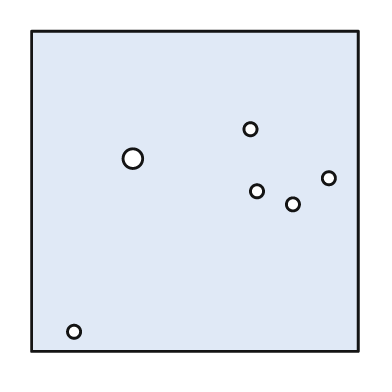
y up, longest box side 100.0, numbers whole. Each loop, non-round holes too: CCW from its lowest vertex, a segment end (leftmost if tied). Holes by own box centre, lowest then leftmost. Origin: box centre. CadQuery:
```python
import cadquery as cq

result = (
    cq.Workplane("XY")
    .moveTo(-50.0, -49.0)
    .lineTo(50.0, -49.0)
    .lineTo(50.0, 49.0)
    .lineTo(-50.0, 49.0)
    .close()
    .moveTo(-37.0, -43.0)
    .circle(2.0)
    .moveTo(30.0, -4.0)
    .circle(2.0)
    .moveTo(19.0, 0.0)
    .circle(2.0)
    .moveTo(41.0, 4.0)
    .circle(2.0)
    .moveTo(-19.0, 10.0)
    .circle(3.0)
    .moveTo(17.0, 19.0)
    .circle(2.0)
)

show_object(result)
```